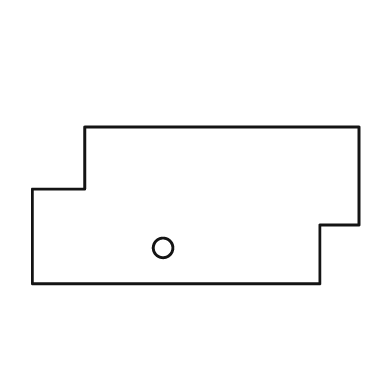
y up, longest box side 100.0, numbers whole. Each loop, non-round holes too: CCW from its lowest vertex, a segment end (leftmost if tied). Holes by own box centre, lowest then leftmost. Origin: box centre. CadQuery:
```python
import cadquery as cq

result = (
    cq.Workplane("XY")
    .moveTo(-50.0, -24.0)
    .lineTo(38.0, -24.0)
    .lineTo(38.0, -6.0)
    .lineTo(50.0, -6.0)
    .lineTo(50.0, 24.0)
    .lineTo(-34.0, 24.0)
    .lineTo(-34.0, 5.0)
    .lineTo(-50.0, 5.0)
    .close()
    .moveTo(-10.0, -13.0)
    .circle(3.0)
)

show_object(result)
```